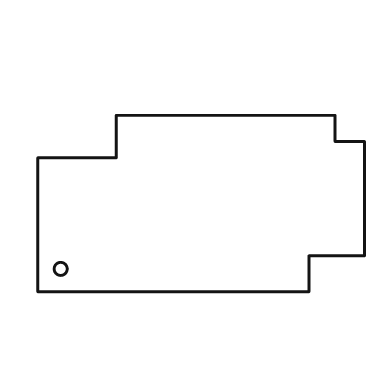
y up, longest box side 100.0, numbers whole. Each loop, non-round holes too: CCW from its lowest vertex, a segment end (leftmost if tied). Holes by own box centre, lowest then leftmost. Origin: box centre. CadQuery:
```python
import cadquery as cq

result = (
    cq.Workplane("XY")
    .moveTo(-50.0, -27.0)
    .lineTo(33.0, -27.0)
    .lineTo(33.0, -16.0)
    .lineTo(50.0, -16.0)
    .lineTo(50.0, 19.0)
    .lineTo(41.0, 19.0)
    .lineTo(41.0, 27.0)
    .lineTo(-26.0, 27.0)
    .lineTo(-26.0, 14.0)
    .lineTo(-50.0, 14.0)
    .close()
    .moveTo(-43.0, -20.0)
    .circle(2.0)
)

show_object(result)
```